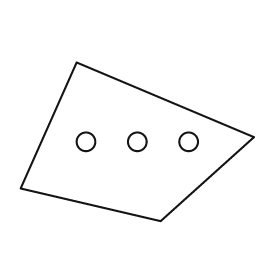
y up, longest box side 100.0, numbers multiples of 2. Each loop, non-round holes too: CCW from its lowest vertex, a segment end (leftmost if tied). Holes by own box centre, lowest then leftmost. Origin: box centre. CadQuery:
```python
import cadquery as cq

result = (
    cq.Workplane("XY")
    .moveTo(10.0, -34.0)
    .lineTo(50.0, 2.0)
    .lineTo(-26.0, 34.0)
    .lineTo(-50.0, -20.0)
    .close()
    .moveTo(-22.0, 0.0)
    .circle(4.0)
    .moveTo(0.0, 0.0)
    .circle(4.0)
    .moveTo(22.0, 0.0)
    .circle(4.0)
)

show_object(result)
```